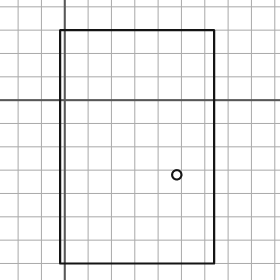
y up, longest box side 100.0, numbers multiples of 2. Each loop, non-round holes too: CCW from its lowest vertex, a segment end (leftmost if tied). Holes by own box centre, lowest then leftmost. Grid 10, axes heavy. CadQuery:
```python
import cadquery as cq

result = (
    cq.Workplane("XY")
    .moveTo(-2.0, -70.0)
    .lineTo(64.0, -70.0)
    .lineTo(64.0, 30.0)
    .lineTo(-2.0, 30.0)
    .close()
    .moveTo(48.0, -32.0)
    .circle(2.0)
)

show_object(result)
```